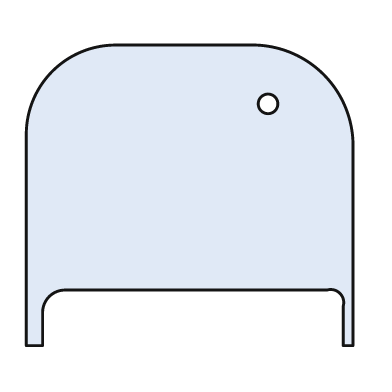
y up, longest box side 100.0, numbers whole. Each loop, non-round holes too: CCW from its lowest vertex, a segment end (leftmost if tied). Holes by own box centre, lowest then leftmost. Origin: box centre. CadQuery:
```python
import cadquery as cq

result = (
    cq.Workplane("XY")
    .moveTo(-50.0, -46.0)
    .lineTo(-45.0, -46.0)
    .lineTo(-45.0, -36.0)
    .threePointArc((-43.0, -31.0), (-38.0, -29.0))
    .lineTo(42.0, -29.0)
    .threePointArc((46.0, -30.0), (47.0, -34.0))
    .lineTo(47.0, -46.0)
    .lineTo(50.0, -46.0)
    .lineTo(50.0, 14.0)
    .threePointArc((41.0, 37.0), (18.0, 46.0))
    .lineTo(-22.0, 46.0)
    .threePointArc((-42.0, 38.0), (-50.0, 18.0))
    .close()
    .moveTo(24.0, 28.0)
    .circle(3.0)
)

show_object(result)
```